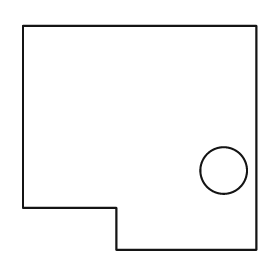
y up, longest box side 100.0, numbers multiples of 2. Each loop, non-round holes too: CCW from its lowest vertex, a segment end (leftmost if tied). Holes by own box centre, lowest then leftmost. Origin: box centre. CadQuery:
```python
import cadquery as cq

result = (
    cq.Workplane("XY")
    .moveTo(-10.0, -48.0)
    .lineTo(50.0, -48.0)
    .lineTo(50.0, 48.0)
    .lineTo(-50.0, 48.0)
    .lineTo(-50.0, -30.0)
    .lineTo(-10.0, -30.0)
    .close()
    .moveTo(36.0, -14.0)
    .circle(10.0)
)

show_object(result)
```